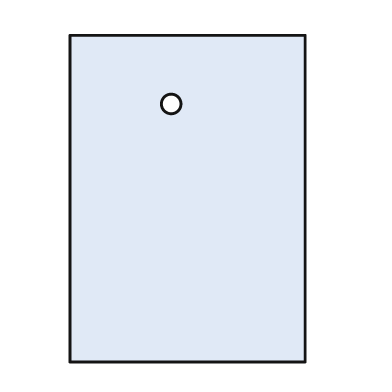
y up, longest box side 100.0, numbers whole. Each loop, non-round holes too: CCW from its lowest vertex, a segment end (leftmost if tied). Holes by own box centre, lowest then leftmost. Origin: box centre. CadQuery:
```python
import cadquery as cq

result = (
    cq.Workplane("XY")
    .moveTo(-36.0, -50.0)
    .lineTo(36.0, -50.0)
    .lineTo(36.0, 50.0)
    .lineTo(-36.0, 50.0)
    .close()
    .moveTo(-5.0, 29.0)
    .circle(3.0)
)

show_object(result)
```